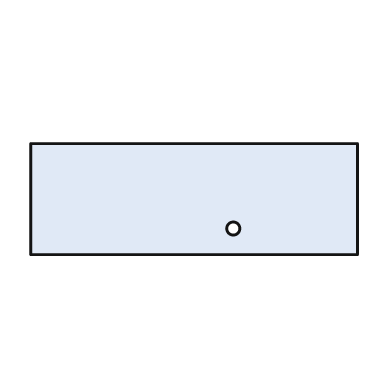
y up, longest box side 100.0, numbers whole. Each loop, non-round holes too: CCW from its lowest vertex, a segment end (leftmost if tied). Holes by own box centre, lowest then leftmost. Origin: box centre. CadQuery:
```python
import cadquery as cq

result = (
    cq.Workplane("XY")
    .moveTo(-50.0, -17.0)
    .lineTo(50.0, -17.0)
    .lineTo(50.0, 17.0)
    .lineTo(-50.0, 17.0)
    .close()
    .moveTo(12.0, -9.0)
    .circle(2.0)
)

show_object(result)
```